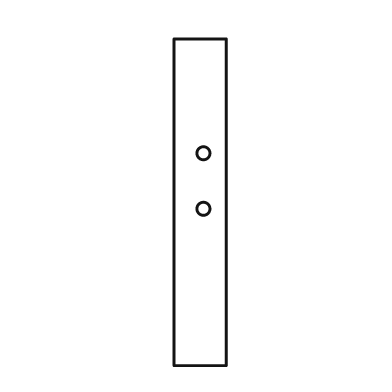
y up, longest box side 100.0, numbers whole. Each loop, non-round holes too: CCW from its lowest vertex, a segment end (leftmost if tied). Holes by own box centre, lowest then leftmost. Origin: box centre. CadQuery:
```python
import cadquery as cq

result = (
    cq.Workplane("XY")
    .moveTo(-8.0, -50.0)
    .lineTo(8.0, -50.0)
    .lineTo(8.0, 50.0)
    .lineTo(-8.0, 50.0)
    .close()
    .moveTo(1.0, -2.0)
    .circle(2.0)
    .moveTo(1.0, 15.0)
    .circle(2.0)
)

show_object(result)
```